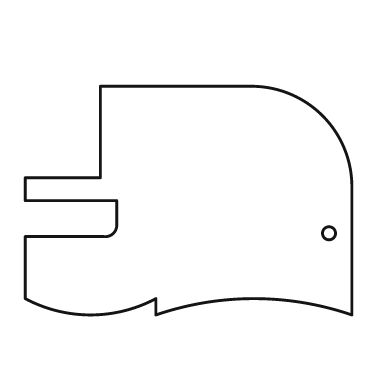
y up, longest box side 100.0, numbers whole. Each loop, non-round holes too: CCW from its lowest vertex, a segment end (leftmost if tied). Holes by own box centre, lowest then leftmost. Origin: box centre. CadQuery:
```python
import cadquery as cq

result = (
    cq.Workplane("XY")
    .moveTo(-10.0, -35.0)
    .threePointArc((20.0, -30.0), (50.0, -35.0))
    .lineTo(50.0, 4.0)
    .threePointArc((41.0, 26.0), (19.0, 35.0))
    .lineTo(-27.0, 35.0)
    .lineTo(-27.0, 7.0)
    .lineTo(-50.0, 7.0)
    .lineTo(-50.0, 0.0)
    .lineTo(-22.0, 0.0)
    .lineTo(-22.0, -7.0)
    .threePointArc((-23.0, -10.0), (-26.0, -11.0))
    .lineTo(-50.0, -11.0)
    .lineTo(-50.0, -30.0)
    .threePointArc((-30.0, -35.0), (-10.0, -30.0))
    .close()
    .moveTo(43.0, -10.0)
    .circle(2.0)
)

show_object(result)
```